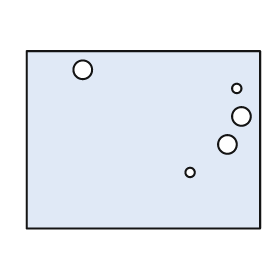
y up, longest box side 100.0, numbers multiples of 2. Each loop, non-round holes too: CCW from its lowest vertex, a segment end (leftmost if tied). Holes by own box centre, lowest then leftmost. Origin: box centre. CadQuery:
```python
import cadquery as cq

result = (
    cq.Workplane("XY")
    .moveTo(-50.0, -38.0)
    .lineTo(50.0, -38.0)
    .lineTo(50.0, 38.0)
    .lineTo(-50.0, 38.0)
    .close()
    .moveTo(20.0, -14.0)
    .circle(2.0)
    .moveTo(36.0, -2.0)
    .circle(4.0)
    .moveTo(42.0, 10.0)
    .circle(4.0)
    .moveTo(40.0, 22.0)
    .circle(2.0)
    .moveTo(-26.0, 30.0)
    .circle(4.0)
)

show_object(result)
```